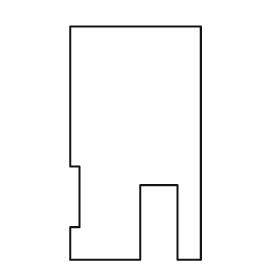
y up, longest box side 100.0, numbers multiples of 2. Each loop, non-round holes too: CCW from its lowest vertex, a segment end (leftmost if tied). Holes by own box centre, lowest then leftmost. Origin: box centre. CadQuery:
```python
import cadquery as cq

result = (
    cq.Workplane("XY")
    .moveTo(-28.0, -50.0)
    .lineTo(2.0, -50.0)
    .lineTo(2.0, -18.0)
    .lineTo(18.0, -18.0)
    .lineTo(18.0, -50.0)
    .lineTo(28.0, -50.0)
    .lineTo(28.0, 50.0)
    .lineTo(-28.0, 50.0)
    .lineTo(-28.0, -10.0)
    .lineTo(-24.0, -10.0)
    .lineTo(-24.0, -36.0)
    .lineTo(-28.0, -36.0)
    .close()
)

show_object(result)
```